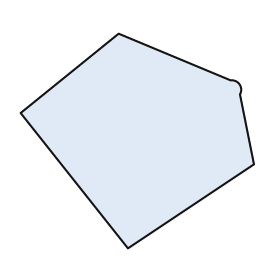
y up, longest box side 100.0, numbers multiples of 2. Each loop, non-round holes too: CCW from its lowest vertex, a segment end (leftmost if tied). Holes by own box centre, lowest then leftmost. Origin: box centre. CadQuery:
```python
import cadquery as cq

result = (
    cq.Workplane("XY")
    .moveTo(-4.0, -46.0)
    .lineTo(50.0, -10.0)
    .lineTo(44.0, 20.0)
    .threePointArc((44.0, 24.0), (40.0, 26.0))
    .lineTo(-8.0, 46.0)
    .lineTo(-50.0, 12.0)
    .close()
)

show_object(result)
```